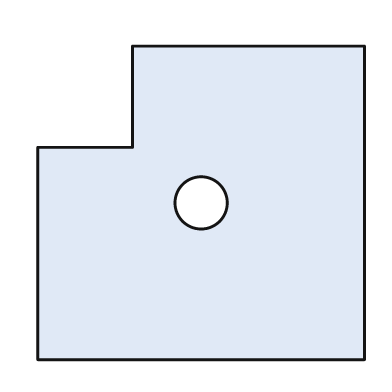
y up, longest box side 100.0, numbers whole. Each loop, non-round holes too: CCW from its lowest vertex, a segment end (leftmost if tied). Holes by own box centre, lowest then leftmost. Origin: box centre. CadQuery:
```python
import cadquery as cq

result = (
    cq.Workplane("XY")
    .moveTo(-50.0, -48.0)
    .lineTo(50.0, -48.0)
    .lineTo(50.0, 48.0)
    .lineTo(-21.0, 48.0)
    .lineTo(-21.0, 17.0)
    .lineTo(-50.0, 17.0)
    .close()
    .moveTo(0.0, 0.0)
    .circle(8.0)
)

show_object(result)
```